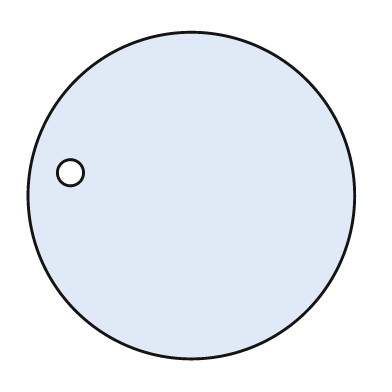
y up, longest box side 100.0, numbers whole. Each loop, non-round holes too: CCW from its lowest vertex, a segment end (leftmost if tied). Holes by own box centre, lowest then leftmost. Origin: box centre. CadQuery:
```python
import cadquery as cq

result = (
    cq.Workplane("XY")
    .moveTo(0.0, 0.0)
    .circle(50.0)
    .moveTo(-37.0, 7.0)
    .circle(4.0)
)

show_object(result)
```